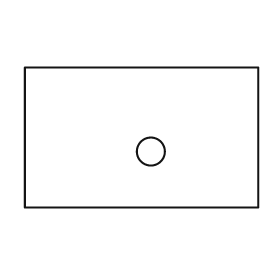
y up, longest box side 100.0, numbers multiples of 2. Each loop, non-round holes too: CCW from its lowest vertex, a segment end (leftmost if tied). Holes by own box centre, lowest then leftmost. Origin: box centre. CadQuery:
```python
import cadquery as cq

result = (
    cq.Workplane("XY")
    .moveTo(-50.0, -30.0)
    .lineTo(50.0, -30.0)
    .lineTo(50.0, 30.0)
    .lineTo(-50.0, 30.0)
    .close()
    .moveTo(4.0, -6.0)
    .circle(6.0)
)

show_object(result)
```